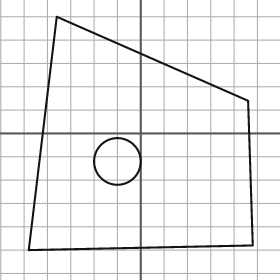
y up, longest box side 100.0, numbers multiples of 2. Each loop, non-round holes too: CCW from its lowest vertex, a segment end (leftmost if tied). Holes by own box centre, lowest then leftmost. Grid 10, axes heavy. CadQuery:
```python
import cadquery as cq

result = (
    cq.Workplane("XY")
    .moveTo(-48.0, -50.0)
    .lineTo(48.0, -48.0)
    .lineTo(46.0, 14.0)
    .lineTo(-36.0, 50.0)
    .close()
    .moveTo(-10.0, -12.0)
    .circle(10.0)
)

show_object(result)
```